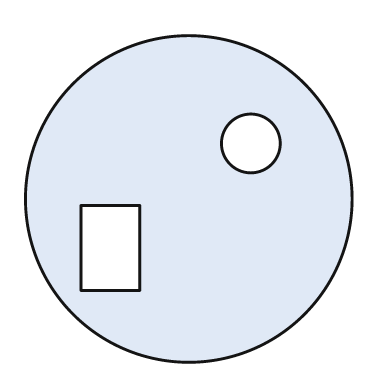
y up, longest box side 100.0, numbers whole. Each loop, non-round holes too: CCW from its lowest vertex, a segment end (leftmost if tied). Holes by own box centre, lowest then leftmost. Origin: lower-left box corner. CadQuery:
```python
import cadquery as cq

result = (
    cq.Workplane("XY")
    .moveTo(50.0, 50.0)
    .circle(50.0)
    .moveTo(17.0, 22.0)
    .lineTo(35.0, 22.0)
    .lineTo(35.0, 48.0)
    .lineTo(17.0, 48.0)
    .close()
    .moveTo(69.0, 67.0)
    .circle(9.0)
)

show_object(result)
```